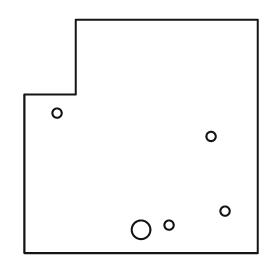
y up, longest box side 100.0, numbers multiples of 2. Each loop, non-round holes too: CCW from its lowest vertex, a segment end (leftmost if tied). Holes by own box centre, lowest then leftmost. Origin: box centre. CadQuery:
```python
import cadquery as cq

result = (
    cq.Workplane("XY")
    .moveTo(-50.0, -50.0)
    .lineTo(50.0, -50.0)
    .lineTo(50.0, 50.0)
    .lineTo(-28.0, 50.0)
    .lineTo(-28.0, 18.0)
    .lineTo(-50.0, 18.0)
    .close()
    .moveTo(0.0, -40.0)
    .circle(4.0)
    .moveTo(12.0, -38.0)
    .circle(2.0)
    .moveTo(36.0, -32.0)
    .circle(2.0)
    .moveTo(30.0, 0.0)
    .circle(2.0)
    .moveTo(-36.0, 10.0)
    .circle(2.0)
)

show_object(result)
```